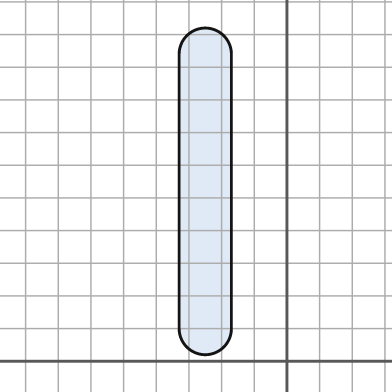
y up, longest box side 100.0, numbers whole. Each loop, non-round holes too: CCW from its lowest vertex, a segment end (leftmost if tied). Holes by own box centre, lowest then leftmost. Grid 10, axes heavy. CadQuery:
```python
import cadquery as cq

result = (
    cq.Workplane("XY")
    .moveTo(-33.0, 10.0)
    .threePointArc((-25.0, 2.0), (-17.0, 10.0))
    .lineTo(-17.0, 94.0)
    .threePointArc((-25.0, 102.0), (-33.0, 94.0))
    .close()
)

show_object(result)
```